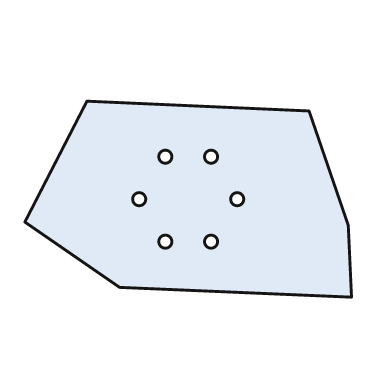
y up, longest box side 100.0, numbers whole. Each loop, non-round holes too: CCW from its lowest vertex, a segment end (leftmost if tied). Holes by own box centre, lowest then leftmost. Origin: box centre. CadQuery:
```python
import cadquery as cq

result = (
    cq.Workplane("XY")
    .moveTo(50.0, -30.0)
    .lineTo(49.0, -8.0)
    .lineTo(37.0, 27.0)
    .lineTo(-31.0, 30.0)
    .lineTo(-50.0, -7.0)
    .lineTo(-21.0, -27.0)
    .close()
    .moveTo(-7.0, -13.0)
    .circle(2.0)
    .moveTo(7.0, -13.0)
    .circle(2.0)
    .moveTo(-15.0, 0.0)
    .circle(2.0)
    .moveTo(15.0, 0.0)
    .circle(2.0)
    .moveTo(-7.0, 13.0)
    .circle(2.0)
    .moveTo(7.0, 13.0)
    .circle(2.0)
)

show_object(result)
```